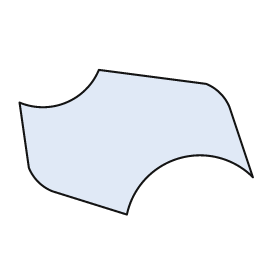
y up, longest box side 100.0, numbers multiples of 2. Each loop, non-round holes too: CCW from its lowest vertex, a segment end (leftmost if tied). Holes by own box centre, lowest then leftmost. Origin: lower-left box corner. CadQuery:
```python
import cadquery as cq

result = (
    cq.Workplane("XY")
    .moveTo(46.0, 0.0)
    .threePointArc((68.0, 24.0), (100.0, 16.0))
    .lineTo(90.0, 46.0)
    .threePointArc((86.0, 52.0), (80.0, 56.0))
    .lineTo(34.0, 62.0)
    .threePointArc((20.0, 48.0), (0.0, 48.0))
    .lineTo(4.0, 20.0)
    .threePointArc((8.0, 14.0), (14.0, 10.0))
    .close()
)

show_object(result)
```